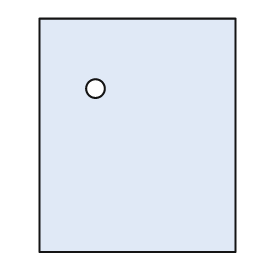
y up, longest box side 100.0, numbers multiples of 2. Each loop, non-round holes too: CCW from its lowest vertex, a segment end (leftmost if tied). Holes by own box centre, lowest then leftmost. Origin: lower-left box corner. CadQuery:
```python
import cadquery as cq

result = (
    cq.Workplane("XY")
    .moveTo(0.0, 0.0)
    .lineTo(84.0, 0.0)
    .lineTo(84.0, 100.0)
    .lineTo(0.0, 100.0)
    .close()
    .moveTo(24.0, 70.0)
    .circle(4.0)
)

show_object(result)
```